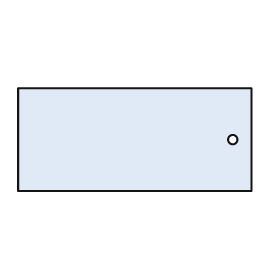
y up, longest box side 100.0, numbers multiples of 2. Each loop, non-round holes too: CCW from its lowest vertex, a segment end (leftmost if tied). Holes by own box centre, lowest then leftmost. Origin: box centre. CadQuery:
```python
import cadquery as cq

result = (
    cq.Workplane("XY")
    .moveTo(-50.0, -22.0)
    .lineTo(50.0, -22.0)
    .lineTo(50.0, 22.0)
    .lineTo(-50.0, 22.0)
    .close()
    .moveTo(42.0, 0.0)
    .circle(2.0)
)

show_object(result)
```